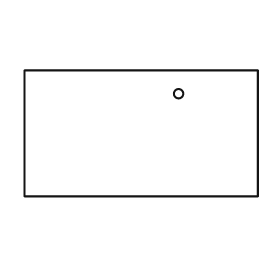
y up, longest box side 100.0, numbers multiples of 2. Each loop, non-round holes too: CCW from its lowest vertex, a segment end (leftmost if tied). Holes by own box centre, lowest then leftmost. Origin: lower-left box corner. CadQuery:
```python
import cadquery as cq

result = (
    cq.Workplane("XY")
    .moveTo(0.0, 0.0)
    .lineTo(100.0, 0.0)
    .lineTo(100.0, 54.0)
    .lineTo(0.0, 54.0)
    .close()
    .moveTo(66.0, 44.0)
    .circle(2.0)
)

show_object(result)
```